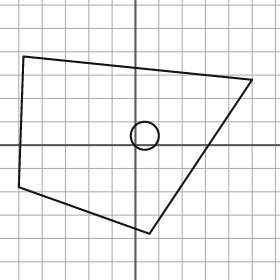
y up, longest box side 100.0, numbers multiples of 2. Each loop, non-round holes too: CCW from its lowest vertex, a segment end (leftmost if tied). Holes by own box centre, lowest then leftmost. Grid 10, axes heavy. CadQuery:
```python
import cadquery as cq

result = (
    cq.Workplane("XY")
    .moveTo(6.0, -38.0)
    .lineTo(50.0, 28.0)
    .lineTo(-48.0, 38.0)
    .lineTo(-50.0, -18.0)
    .close()
    .moveTo(4.0, 4.0)
    .circle(6.0)
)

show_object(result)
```